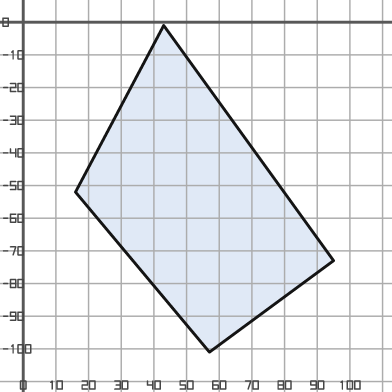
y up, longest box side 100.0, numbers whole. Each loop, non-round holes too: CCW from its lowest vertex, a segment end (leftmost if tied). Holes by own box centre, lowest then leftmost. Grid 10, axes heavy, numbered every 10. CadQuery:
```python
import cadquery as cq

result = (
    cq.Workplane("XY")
    .moveTo(57.0, -101.0)
    .lineTo(95.0, -73.0)
    .lineTo(43.0, -1.0)
    .lineTo(16.0, -52.0)
    .close()
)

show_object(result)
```